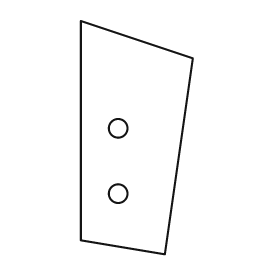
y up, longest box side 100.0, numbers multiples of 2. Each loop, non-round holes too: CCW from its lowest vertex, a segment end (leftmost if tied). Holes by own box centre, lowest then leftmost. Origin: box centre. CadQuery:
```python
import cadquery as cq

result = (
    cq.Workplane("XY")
    .moveTo(12.0, -50.0)
    .lineTo(24.0, 34.0)
    .lineTo(-24.0, 50.0)
    .lineTo(-24.0, -44.0)
    .close()
    .moveTo(-8.0, -24.0)
    .circle(4.0)
    .moveTo(-8.0, 4.0)
    .circle(4.0)
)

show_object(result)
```